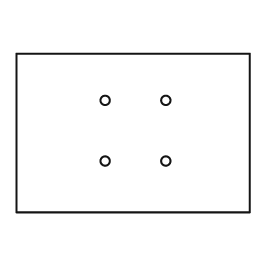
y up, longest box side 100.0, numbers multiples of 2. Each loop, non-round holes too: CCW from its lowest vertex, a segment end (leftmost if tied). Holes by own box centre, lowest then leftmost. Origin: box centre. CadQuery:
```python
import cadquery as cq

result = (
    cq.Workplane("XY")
    .moveTo(-50.0, -34.0)
    .lineTo(50.0, -34.0)
    .lineTo(50.0, 34.0)
    .lineTo(-50.0, 34.0)
    .close()
    .moveTo(-12.0, -12.0)
    .circle(2.0)
    .moveTo(14.0, -12.0)
    .circle(2.0)
    .moveTo(-12.0, 14.0)
    .circle(2.0)
    .moveTo(14.0, 14.0)
    .circle(2.0)
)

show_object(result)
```